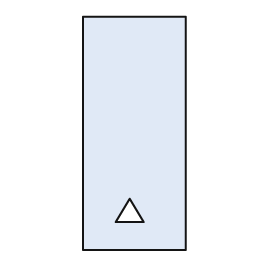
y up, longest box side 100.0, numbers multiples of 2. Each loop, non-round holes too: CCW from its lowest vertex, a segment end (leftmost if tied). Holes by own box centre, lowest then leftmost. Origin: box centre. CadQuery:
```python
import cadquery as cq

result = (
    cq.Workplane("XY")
    .moveTo(-22.0, -50.0)
    .lineTo(22.0, -50.0)
    .lineTo(22.0, 50.0)
    .lineTo(-22.0, 50.0)
    .close()
    .moveTo(-8.0, -38.0)
    .lineTo(4.0, -38.0)
    .lineTo(-2.0, -28.0)
    .close()
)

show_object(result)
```